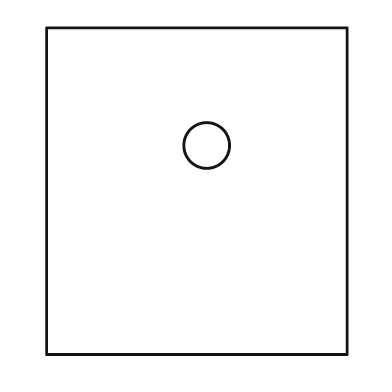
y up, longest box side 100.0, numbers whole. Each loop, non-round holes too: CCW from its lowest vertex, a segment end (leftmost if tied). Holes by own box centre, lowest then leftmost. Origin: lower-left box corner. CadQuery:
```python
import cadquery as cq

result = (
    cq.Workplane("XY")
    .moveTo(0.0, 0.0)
    .lineTo(92.0, 0.0)
    .lineTo(92.0, 100.0)
    .lineTo(0.0, 100.0)
    .close()
    .moveTo(49.0, 64.0)
    .circle(7.0)
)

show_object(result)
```